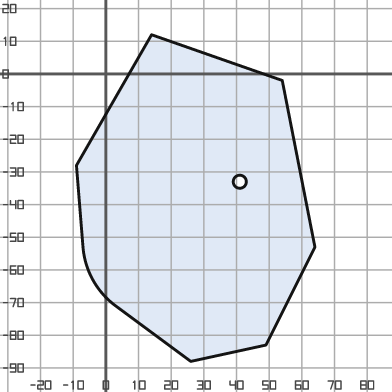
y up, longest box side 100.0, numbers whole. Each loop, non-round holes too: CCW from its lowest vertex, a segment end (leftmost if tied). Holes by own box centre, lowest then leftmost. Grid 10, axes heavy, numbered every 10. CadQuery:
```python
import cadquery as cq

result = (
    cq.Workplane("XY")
    .moveTo(26.0, -88.0)
    .lineTo(49.0, -83.0)
    .lineTo(64.0, -53.0)
    .lineTo(54.0, -2.0)
    .lineTo(14.0, 12.0)
    .lineTo(-9.0, -28.0)
    .lineTo(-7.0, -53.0)
    .threePointArc((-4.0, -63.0), (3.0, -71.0))
    .close()
    .moveTo(41.0, -33.0)
    .circle(2.0)
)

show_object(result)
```